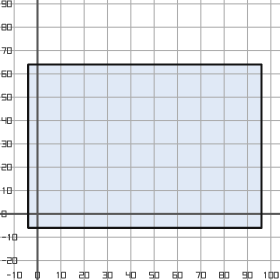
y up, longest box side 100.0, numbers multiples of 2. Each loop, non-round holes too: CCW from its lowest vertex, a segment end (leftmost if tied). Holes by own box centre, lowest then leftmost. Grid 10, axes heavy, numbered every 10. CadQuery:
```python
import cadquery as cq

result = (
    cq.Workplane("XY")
    .moveTo(-4.0, -6.0)
    .lineTo(96.0, -6.0)
    .lineTo(96.0, 64.0)
    .lineTo(-4.0, 64.0)
    .close()
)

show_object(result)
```